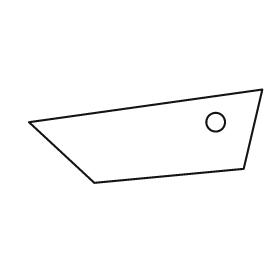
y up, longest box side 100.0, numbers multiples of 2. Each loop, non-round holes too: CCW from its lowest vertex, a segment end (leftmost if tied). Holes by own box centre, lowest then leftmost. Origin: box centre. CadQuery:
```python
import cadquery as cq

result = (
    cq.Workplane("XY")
    .moveTo(-22.0, -20.0)
    .lineTo(42.0, -14.0)
    .lineTo(50.0, 20.0)
    .lineTo(-50.0, 6.0)
    .close()
    .moveTo(30.0, 6.0)
    .circle(4.0)
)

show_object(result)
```